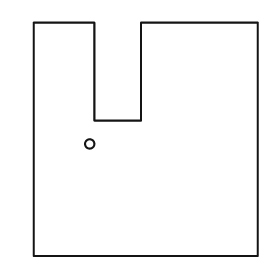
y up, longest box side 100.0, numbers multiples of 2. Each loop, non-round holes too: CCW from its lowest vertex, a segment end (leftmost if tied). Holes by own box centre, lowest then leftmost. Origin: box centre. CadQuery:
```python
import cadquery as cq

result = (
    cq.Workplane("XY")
    .moveTo(-48.0, -50.0)
    .lineTo(48.0, -50.0)
    .lineTo(48.0, 50.0)
    .lineTo(-2.0, 50.0)
    .lineTo(-2.0, 8.0)
    .lineTo(-22.0, 8.0)
    .lineTo(-22.0, 50.0)
    .lineTo(-48.0, 50.0)
    .close()
    .moveTo(-24.0, -2.0)
    .circle(2.0)
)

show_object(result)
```